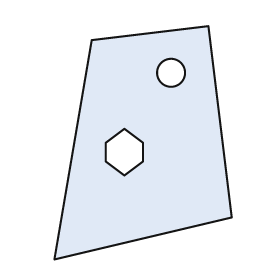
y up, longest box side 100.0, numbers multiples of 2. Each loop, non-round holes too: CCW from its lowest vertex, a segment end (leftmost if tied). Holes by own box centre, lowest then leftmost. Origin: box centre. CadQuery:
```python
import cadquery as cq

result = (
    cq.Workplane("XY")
    .moveTo(-38.0, -50.0)
    .lineTo(38.0, -32.0)
    .lineTo(28.0, 50.0)
    .lineTo(-22.0, 44.0)
    .close()
    .moveTo(-8.0, -14.0)
    .lineTo(0.0, -8.0)
    .lineTo(0.0, 0.0)
    .lineTo(-8.0, 6.0)
    .lineTo(-16.0, 0.0)
    .lineTo(-16.0, -8.0)
    .close()
    .moveTo(12.0, 30.0)
    .circle(6.0)
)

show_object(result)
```